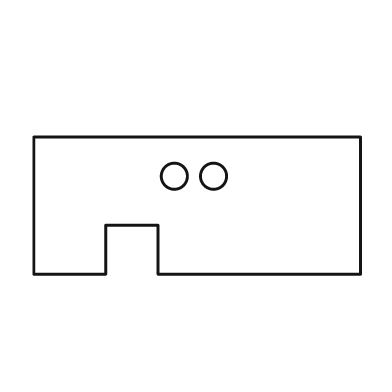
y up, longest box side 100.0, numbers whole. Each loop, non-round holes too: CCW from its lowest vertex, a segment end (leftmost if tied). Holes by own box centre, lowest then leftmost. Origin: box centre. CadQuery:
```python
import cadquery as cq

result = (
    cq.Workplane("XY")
    .moveTo(-50.0, -21.0)
    .lineTo(-28.0, -21.0)
    .lineTo(-28.0, -6.0)
    .lineTo(-12.0, -6.0)
    .lineTo(-12.0, -21.0)
    .lineTo(50.0, -21.0)
    .lineTo(50.0, 21.0)
    .lineTo(-50.0, 21.0)
    .close()
    .moveTo(-7.0, 9.0)
    .circle(4.0)
    .moveTo(5.0, 9.0)
    .circle(4.0)
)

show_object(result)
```